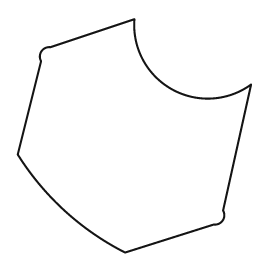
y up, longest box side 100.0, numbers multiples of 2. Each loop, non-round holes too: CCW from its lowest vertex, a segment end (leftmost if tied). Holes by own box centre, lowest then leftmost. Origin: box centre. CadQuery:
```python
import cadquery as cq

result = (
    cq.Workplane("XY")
    .moveTo(-4.0, -50.0)
    .lineTo(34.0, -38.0)
    .threePointArc((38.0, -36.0), (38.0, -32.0))
    .lineTo(50.0, 22.0)
    .threePointArc((16.0, 20.0), (0.0, 50.0))
    .lineTo(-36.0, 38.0)
    .threePointArc((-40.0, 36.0), (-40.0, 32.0))
    .lineTo(-50.0, -8.0)
    .threePointArc((-30.0, -32.0), (-4.0, -50.0))
    .close()
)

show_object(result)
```